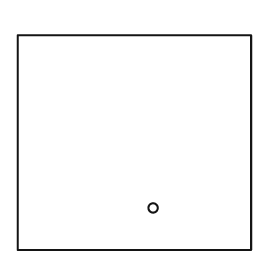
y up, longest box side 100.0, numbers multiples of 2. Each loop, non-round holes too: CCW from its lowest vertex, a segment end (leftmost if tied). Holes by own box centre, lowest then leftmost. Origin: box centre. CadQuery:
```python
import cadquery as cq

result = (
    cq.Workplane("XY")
    .moveTo(-50.0, -46.0)
    .lineTo(50.0, -46.0)
    .lineTo(50.0, 46.0)
    .lineTo(-50.0, 46.0)
    .close()
    .moveTo(8.0, -28.0)
    .circle(2.0)
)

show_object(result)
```